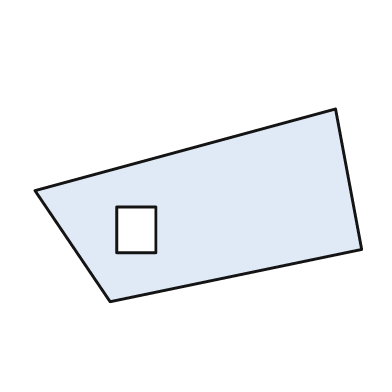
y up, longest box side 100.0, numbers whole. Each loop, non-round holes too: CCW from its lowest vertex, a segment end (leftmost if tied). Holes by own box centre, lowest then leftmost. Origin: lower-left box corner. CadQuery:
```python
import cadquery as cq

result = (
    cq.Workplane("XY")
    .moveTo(23.0, 0.0)
    .lineTo(100.0, 16.0)
    .lineTo(92.0, 59.0)
    .lineTo(0.0, 34.0)
    .close()
    .moveTo(25.0, 15.0)
    .lineTo(37.0, 15.0)
    .lineTo(37.0, 29.0)
    .lineTo(25.0, 29.0)
    .close()
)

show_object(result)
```